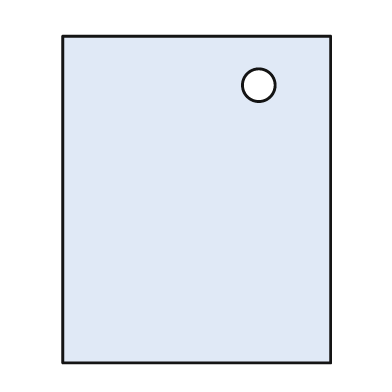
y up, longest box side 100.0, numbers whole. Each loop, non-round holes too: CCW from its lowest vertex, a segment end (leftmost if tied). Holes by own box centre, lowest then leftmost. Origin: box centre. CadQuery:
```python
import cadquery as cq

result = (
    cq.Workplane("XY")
    .moveTo(-41.0, -50.0)
    .lineTo(41.0, -50.0)
    .lineTo(41.0, 50.0)
    .lineTo(-41.0, 50.0)
    .close()
    .moveTo(19.0, 35.0)
    .circle(5.0)
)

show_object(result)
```